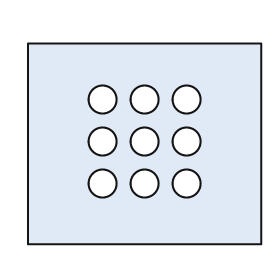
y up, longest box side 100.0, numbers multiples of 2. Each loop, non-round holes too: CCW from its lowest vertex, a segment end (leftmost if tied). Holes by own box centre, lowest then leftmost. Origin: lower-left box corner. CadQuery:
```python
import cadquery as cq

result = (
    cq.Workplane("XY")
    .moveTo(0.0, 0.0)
    .lineTo(100.0, 0.0)
    .lineTo(100.0, 86.0)
    .lineTo(0.0, 86.0)
    .close()
    .moveTo(32.0, 26.0)
    .circle(6.0)
    .moveTo(50.0, 26.0)
    .circle(6.0)
    .moveTo(68.0, 26.0)
    .circle(6.0)
    .moveTo(32.0, 44.0)
    .circle(6.0)
    .moveTo(50.0, 44.0)
    .circle(6.0)
    .moveTo(68.0, 44.0)
    .circle(6.0)
    .moveTo(32.0, 62.0)
    .circle(6.0)
    .moveTo(50.0, 62.0)
    .circle(6.0)
    .moveTo(68.0, 62.0)
    .circle(6.0)
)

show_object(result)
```